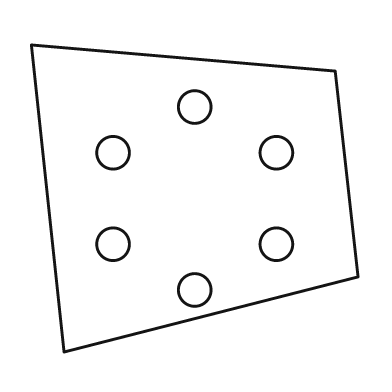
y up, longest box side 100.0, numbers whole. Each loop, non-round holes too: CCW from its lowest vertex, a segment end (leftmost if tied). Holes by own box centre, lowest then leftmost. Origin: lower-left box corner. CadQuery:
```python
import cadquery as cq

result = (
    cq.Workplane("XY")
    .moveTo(10.0, 0.0)
    .lineTo(100.0, 23.0)
    .lineTo(93.0, 86.0)
    .lineTo(0.0, 94.0)
    .close()
    .moveTo(50.0, 19.0)
    .circle(5.0)
    .moveTo(25.0, 33.0)
    .circle(5.0)
    .moveTo(75.0, 33.0)
    .circle(5.0)
    .moveTo(25.0, 61.0)
    .circle(5.0)
    .moveTo(75.0, 61.0)
    .circle(5.0)
    .moveTo(50.0, 75.0)
    .circle(5.0)
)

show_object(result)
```